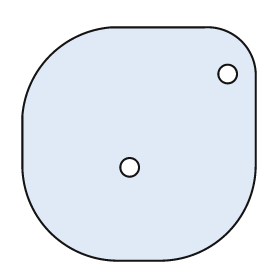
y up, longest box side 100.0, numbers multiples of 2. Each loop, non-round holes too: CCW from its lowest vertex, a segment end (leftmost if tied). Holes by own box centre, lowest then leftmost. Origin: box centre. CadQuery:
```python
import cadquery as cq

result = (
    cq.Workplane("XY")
    .moveTo(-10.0, -50.0)
    .lineTo(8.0, -50.0)
    .threePointArc((38.0, -38.0), (50.0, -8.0))
    .lineTo(50.0, 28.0)
    .threePointArc((44.0, 44.0), (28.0, 50.0))
    .lineTo(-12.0, 50.0)
    .threePointArc((-38.0, 38.0), (-50.0, 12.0))
    .lineTo(-50.0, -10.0)
    .threePointArc((-38.0, -38.0), (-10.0, -50.0))
    .close()
    .moveTo(-4.0, -10.0)
    .circle(4.0)
    .moveTo(38.0, 30.0)
    .circle(4.0)
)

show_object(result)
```